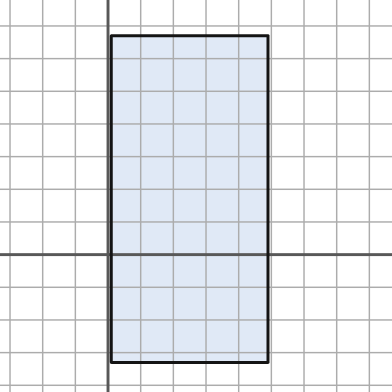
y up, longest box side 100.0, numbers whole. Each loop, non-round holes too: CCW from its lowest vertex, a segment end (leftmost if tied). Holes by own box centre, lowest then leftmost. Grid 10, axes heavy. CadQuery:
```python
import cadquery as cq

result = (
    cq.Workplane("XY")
    .moveTo(1.0, -33.0)
    .lineTo(49.0, -33.0)
    .lineTo(49.0, 67.0)
    .lineTo(1.0, 67.0)
    .close()
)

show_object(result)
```